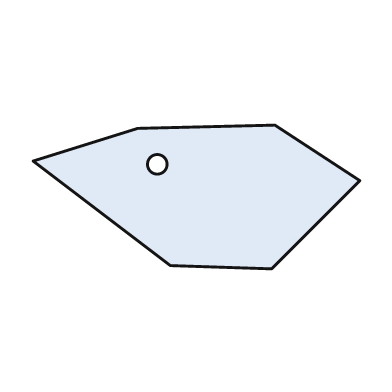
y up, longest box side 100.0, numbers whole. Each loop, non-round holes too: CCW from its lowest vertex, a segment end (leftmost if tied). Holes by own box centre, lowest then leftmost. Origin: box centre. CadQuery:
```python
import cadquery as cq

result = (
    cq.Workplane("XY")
    .moveTo(23.0, -22.0)
    .lineTo(50.0, 5.0)
    .lineTo(24.0, 22.0)
    .lineTo(-18.0, 21.0)
    .lineTo(-50.0, 11.0)
    .lineTo(-8.0, -21.0)
    .close()
    .moveTo(-12.0, 10.0)
    .circle(3.0)
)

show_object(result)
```